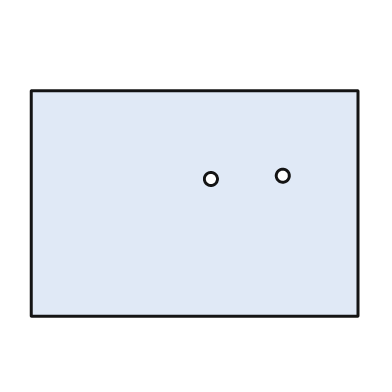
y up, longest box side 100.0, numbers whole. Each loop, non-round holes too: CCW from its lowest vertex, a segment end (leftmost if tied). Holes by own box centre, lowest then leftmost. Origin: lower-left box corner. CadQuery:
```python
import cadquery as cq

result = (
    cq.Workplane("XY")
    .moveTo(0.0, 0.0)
    .lineTo(100.0, 0.0)
    .lineTo(100.0, 69.0)
    .lineTo(0.0, 69.0)
    .close()
    .moveTo(55.0, 42.0)
    .circle(2.0)
    .moveTo(77.0, 43.0)
    .circle(2.0)
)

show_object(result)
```